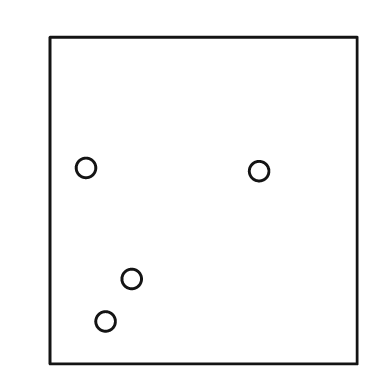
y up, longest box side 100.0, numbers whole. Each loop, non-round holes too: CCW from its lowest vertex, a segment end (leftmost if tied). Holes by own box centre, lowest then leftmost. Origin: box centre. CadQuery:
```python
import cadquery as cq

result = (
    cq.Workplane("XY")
    .moveTo(-47.0, -50.0)
    .lineTo(47.0, -50.0)
    .lineTo(47.0, 50.0)
    .lineTo(-47.0, 50.0)
    .close()
    .moveTo(-30.0, -37.0)
    .circle(3.0)
    .moveTo(-22.0, -24.0)
    .circle(3.0)
    .moveTo(17.0, 9.0)
    .circle(3.0)
    .moveTo(-36.0, 10.0)
    .circle(3.0)
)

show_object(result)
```